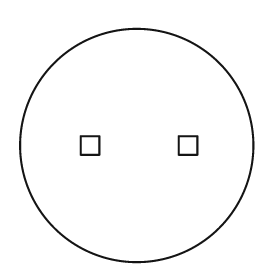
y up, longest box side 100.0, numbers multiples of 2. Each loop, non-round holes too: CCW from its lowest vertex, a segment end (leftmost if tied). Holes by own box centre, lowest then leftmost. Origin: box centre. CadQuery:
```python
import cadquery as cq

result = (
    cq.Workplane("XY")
    .moveTo(0.0, 0.0)
    .circle(50.0)
    .moveTo(-24.0, -4.0)
    .lineTo(-16.0, -4.0)
    .lineTo(-16.0, 4.0)
    .lineTo(-24.0, 4.0)
    .close()
    .moveTo(18.0, -4.0)
    .lineTo(26.0, -4.0)
    .lineTo(26.0, 4.0)
    .lineTo(18.0, 4.0)
    .close()
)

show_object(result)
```